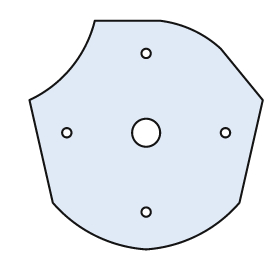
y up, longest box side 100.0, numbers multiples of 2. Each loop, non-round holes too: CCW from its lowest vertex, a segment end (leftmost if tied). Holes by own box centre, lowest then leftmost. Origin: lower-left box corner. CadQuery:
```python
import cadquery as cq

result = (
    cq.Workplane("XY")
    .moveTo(50.0, 0.0)
    .threePointArc((72.0, 6.0), (90.0, 20.0))
    .lineTo(100.0, 64.0)
    .lineTo(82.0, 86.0)
    .threePointArc((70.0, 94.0), (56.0, 98.0))
    .lineTo(28.0, 98.0)
    .threePointArc((18.0, 78.0), (0.0, 64.0))
    .lineTo(10.0, 20.0)
    .threePointArc((28.0, 6.0), (50.0, 0.0))
    .close()
    .moveTo(50.0, 16.0)
    .circle(2.0)
    .moveTo(16.0, 50.0)
    .circle(2.0)
    .moveTo(50.0, 50.0)
    .circle(6.0)
    .moveTo(84.0, 50.0)
    .circle(2.0)
    .moveTo(50.0, 84.0)
    .circle(2.0)
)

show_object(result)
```